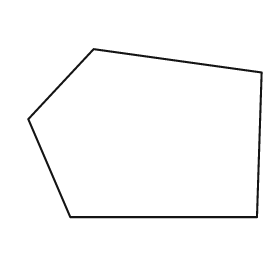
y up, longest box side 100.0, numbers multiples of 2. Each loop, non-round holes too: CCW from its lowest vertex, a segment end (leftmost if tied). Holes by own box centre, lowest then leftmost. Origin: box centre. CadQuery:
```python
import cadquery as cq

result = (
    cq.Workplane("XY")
    .moveTo(-32.0, -36.0)
    .lineTo(48.0, -36.0)
    .lineTo(50.0, 26.0)
    .lineTo(-22.0, 36.0)
    .lineTo(-50.0, 6.0)
    .close()
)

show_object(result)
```